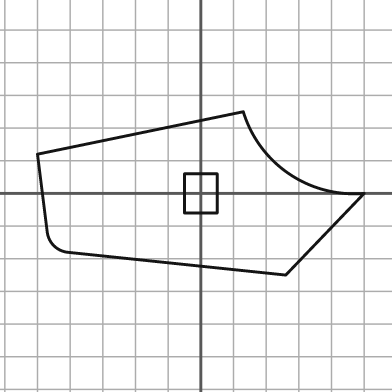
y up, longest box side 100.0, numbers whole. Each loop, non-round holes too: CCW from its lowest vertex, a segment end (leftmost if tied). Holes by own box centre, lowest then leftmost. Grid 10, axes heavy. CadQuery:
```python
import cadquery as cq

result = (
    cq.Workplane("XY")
    .moveTo(26.0, -25.0)
    .lineTo(50.0, 0.0)
    .threePointArc((27.0, 6.0), (13.0, 25.0))
    .lineTo(-50.0, 12.0)
    .lineTo(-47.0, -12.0)
    .threePointArc((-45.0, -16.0), (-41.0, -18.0))
    .close()
    .moveTo(-5.0, -6.0)
    .lineTo(5.0, -6.0)
    .lineTo(5.0, 6.0)
    .lineTo(-5.0, 6.0)
    .close()
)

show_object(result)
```